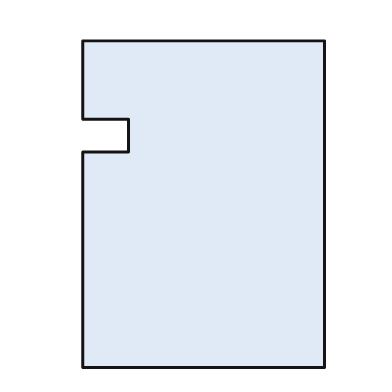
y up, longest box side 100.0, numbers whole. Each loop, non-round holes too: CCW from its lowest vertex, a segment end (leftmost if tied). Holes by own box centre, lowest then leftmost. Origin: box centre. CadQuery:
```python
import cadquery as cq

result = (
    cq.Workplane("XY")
    .moveTo(-37.0, -50.0)
    .lineTo(37.0, -50.0)
    .lineTo(37.0, 50.0)
    .lineTo(-37.0, 50.0)
    .lineTo(-37.0, 26.0)
    .lineTo(-23.0, 26.0)
    .lineTo(-23.0, 16.0)
    .lineTo(-37.0, 16.0)
    .close()
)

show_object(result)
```